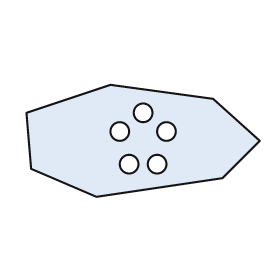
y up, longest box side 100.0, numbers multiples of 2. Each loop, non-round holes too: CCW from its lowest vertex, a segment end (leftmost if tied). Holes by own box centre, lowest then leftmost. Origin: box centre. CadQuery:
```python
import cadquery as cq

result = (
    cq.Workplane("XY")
    .moveTo(-20.0, -24.0)
    .lineTo(34.0, -16.0)
    .lineTo(50.0, 0.0)
    .lineTo(30.0, 18.0)
    .lineTo(-14.0, 24.0)
    .lineTo(-50.0, 12.0)
    .lineTo(-48.0, -12.0)
    .close()
    .moveTo(-6.0, -10.0)
    .circle(4.0)
    .moveTo(6.0, -10.0)
    .circle(4.0)
    .moveTo(-10.0, 4.0)
    .circle(4.0)
    .moveTo(10.0, 4.0)
    .circle(4.0)
    .moveTo(0.0, 12.0)
    .circle(4.0)
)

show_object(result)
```